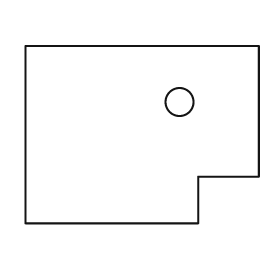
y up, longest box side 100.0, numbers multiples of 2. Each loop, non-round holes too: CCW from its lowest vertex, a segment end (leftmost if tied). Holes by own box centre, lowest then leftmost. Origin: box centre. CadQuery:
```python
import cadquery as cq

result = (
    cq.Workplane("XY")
    .moveTo(-50.0, -38.0)
    .lineTo(24.0, -38.0)
    .lineTo(24.0, -18.0)
    .lineTo(50.0, -18.0)
    .lineTo(50.0, 38.0)
    .lineTo(-50.0, 38.0)
    .close()
    .moveTo(16.0, 14.0)
    .circle(6.0)
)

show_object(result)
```